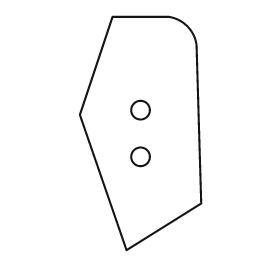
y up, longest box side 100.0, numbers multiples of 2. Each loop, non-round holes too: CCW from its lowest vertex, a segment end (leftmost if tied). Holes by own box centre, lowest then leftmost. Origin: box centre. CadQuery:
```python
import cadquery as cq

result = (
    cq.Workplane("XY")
    .moveTo(-6.0, -50.0)
    .lineTo(26.0, -30.0)
    .lineTo(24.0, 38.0)
    .threePointArc((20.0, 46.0), (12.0, 50.0))
    .lineTo(-12.0, 50.0)
    .lineTo(-26.0, 8.0)
    .close()
    .moveTo(0.0, -10.0)
    .circle(4.0)
    .moveTo(0.0, 10.0)
    .circle(4.0)
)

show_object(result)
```